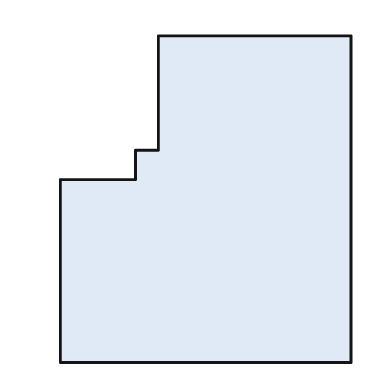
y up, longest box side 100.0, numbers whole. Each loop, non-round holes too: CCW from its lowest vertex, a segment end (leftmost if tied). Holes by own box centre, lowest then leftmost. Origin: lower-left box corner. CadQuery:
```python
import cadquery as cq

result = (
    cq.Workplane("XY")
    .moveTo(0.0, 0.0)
    .lineTo(89.0, 0.0)
    .lineTo(89.0, 100.0)
    .lineTo(30.0, 100.0)
    .lineTo(30.0, 65.0)
    .lineTo(23.0, 65.0)
    .lineTo(23.0, 56.0)
    .lineTo(0.0, 56.0)
    .close()
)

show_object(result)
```